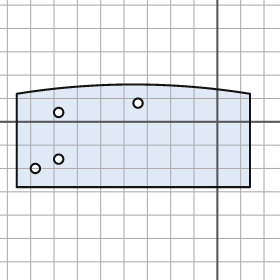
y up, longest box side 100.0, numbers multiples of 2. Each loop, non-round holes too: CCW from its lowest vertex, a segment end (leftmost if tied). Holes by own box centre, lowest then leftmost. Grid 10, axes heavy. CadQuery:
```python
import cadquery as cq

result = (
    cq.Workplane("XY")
    .moveTo(-86.0, -28.0)
    .lineTo(14.0, -28.0)
    .lineTo(14.0, 12.0)
    .threePointArc((-36.0, 16.0), (-86.0, 12.0))
    .close()
    .moveTo(-78.0, -20.0)
    .circle(2.0)
    .moveTo(-68.0, -16.0)
    .circle(2.0)
    .moveTo(-68.0, 4.0)
    .circle(2.0)
    .moveTo(-34.0, 8.0)
    .circle(2.0)
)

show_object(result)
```